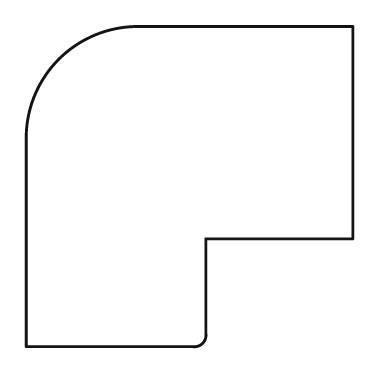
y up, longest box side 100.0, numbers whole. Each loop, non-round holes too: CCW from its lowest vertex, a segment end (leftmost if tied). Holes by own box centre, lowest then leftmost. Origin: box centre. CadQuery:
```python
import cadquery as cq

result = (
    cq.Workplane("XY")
    .moveTo(-50.0, -49.0)
    .lineTo(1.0, -49.0)
    .threePointArc((4.0, -48.0), (5.0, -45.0))
    .lineTo(5.0, -16.0)
    .lineTo(50.0, -16.0)
    .lineTo(50.0, 49.0)
    .lineTo(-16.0, 49.0)
    .threePointArc((-40.0, 39.0), (-50.0, 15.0))
    .close()
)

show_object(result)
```